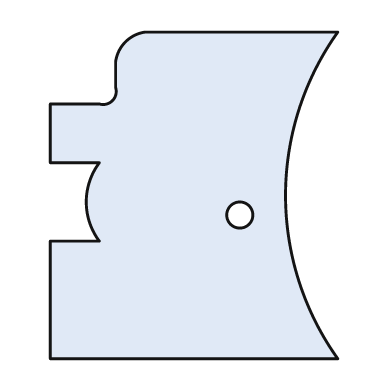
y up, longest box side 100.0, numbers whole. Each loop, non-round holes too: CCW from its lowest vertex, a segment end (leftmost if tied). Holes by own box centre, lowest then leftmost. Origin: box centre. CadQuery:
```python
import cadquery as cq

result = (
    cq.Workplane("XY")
    .moveTo(-44.0, -50.0)
    .lineTo(44.0, -50.0)
    .threePointArc((28.0, 0.0), (44.0, 50.0))
    .lineTo(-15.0, 50.0)
    .threePointArc((-21.0, 47.0), (-24.0, 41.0))
    .lineTo(-24.0, 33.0)
    .threePointArc((-25.0, 29.0), (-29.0, 28.0))
    .lineTo(-44.0, 28.0)
    .lineTo(-44.0, 10.0)
    .lineTo(-29.0, 10.0)
    .threePointArc((-33.0, -2.0), (-29.0, -14.0))
    .lineTo(-44.0, -14.0)
    .close()
    .moveTo(14.0, -6.0)
    .circle(4.0)
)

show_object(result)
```